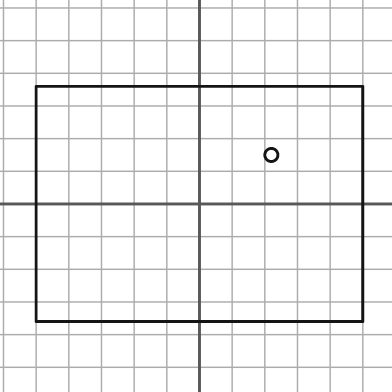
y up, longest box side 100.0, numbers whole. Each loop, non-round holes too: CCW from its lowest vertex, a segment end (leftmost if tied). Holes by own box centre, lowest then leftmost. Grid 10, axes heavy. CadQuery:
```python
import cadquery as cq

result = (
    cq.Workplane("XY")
    .moveTo(-50.0, -36.0)
    .lineTo(50.0, -36.0)
    .lineTo(50.0, 36.0)
    .lineTo(-50.0, 36.0)
    .close()
    .moveTo(22.0, 15.0)
    .circle(2.0)
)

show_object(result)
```